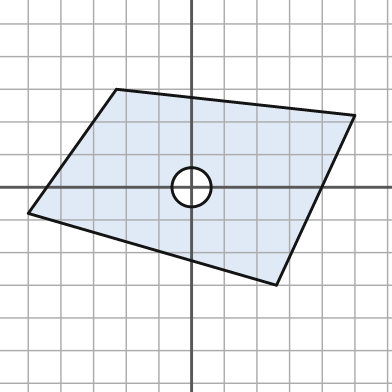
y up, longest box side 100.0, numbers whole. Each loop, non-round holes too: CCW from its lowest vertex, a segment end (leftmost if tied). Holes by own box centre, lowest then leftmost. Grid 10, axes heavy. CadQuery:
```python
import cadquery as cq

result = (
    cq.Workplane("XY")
    .moveTo(26.0, -30.0)
    .lineTo(50.0, 22.0)
    .lineTo(-23.0, 30.0)
    .lineTo(-50.0, -8.0)
    .close()
    .moveTo(0.0, 0.0)
    .circle(6.0)
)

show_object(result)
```